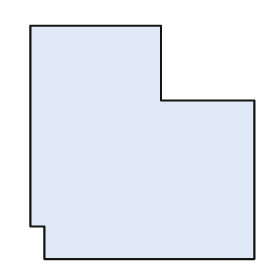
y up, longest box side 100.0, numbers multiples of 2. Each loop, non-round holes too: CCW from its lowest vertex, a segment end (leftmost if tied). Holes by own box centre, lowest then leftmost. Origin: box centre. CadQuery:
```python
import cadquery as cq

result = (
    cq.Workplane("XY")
    .moveTo(-42.0, -50.0)
    .lineTo(48.0, -50.0)
    .lineTo(48.0, 18.0)
    .lineTo(8.0, 18.0)
    .lineTo(8.0, 50.0)
    .lineTo(-48.0, 50.0)
    .lineTo(-48.0, -36.0)
    .lineTo(-42.0, -36.0)
    .close()
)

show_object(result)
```